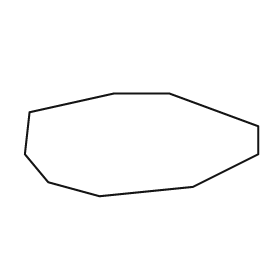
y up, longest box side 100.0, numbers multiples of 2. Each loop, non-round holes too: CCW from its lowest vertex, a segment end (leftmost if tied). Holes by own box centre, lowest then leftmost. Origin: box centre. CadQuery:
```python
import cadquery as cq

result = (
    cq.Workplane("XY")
    .moveTo(-18.0, -22.0)
    .lineTo(22.0, -18.0)
    .lineTo(50.0, -4.0)
    .lineTo(50.0, 8.0)
    .lineTo(12.0, 22.0)
    .lineTo(-12.0, 22.0)
    .lineTo(-48.0, 14.0)
    .lineTo(-50.0, -4.0)
    .lineTo(-40.0, -16.0)
    .close()
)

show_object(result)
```